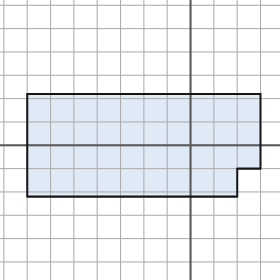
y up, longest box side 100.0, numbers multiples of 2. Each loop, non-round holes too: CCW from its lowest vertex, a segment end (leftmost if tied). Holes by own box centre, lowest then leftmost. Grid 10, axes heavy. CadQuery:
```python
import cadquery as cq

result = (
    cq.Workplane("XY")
    .moveTo(-70.0, -22.0)
    .lineTo(20.0, -22.0)
    .lineTo(20.0, -10.0)
    .lineTo(30.0, -10.0)
    .lineTo(30.0, 22.0)
    .lineTo(-70.0, 22.0)
    .close()
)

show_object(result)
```